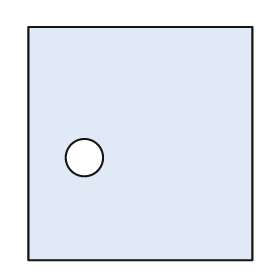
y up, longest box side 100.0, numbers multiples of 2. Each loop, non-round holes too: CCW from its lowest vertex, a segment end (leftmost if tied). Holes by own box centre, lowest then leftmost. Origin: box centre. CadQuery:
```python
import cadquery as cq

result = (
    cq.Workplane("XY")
    .moveTo(-48.0, -50.0)
    .lineTo(48.0, -50.0)
    .lineTo(48.0, 50.0)
    .lineTo(-48.0, 50.0)
    .close()
    .moveTo(-24.0, -6.0)
    .circle(8.0)
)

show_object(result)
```